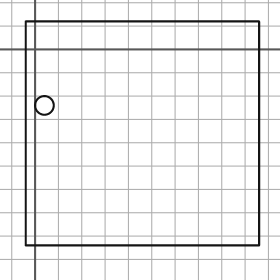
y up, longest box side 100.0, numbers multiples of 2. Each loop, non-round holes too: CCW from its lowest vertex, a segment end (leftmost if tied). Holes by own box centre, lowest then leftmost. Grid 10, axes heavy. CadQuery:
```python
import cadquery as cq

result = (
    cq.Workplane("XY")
    .moveTo(-4.0, -84.0)
    .lineTo(96.0, -84.0)
    .lineTo(96.0, 12.0)
    .lineTo(-4.0, 12.0)
    .close()
    .moveTo(4.0, -24.0)
    .circle(4.0)
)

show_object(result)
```